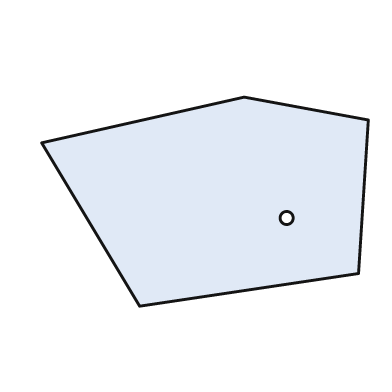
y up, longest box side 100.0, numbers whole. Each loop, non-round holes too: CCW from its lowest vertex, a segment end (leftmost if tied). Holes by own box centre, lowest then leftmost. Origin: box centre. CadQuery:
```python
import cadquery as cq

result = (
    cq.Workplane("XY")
    .moveTo(-20.0, -32.0)
    .lineTo(47.0, -22.0)
    .lineTo(50.0, 25.0)
    .lineTo(12.0, 32.0)
    .lineTo(-50.0, 18.0)
    .close()
    .moveTo(25.0, -5.0)
    .circle(2.0)
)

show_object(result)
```